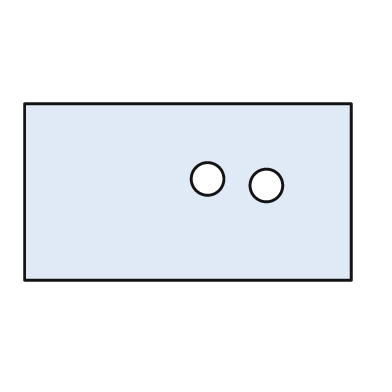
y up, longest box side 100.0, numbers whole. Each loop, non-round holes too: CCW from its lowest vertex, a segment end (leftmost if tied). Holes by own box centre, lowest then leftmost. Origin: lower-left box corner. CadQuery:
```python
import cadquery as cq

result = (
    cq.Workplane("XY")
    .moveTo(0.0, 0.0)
    .lineTo(100.0, 0.0)
    .lineTo(100.0, 54.0)
    .lineTo(0.0, 54.0)
    .close()
    .moveTo(74.0, 29.0)
    .circle(5.0)
    .moveTo(56.0, 31.0)
    .circle(5.0)
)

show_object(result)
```